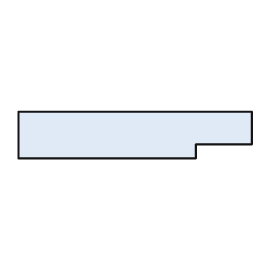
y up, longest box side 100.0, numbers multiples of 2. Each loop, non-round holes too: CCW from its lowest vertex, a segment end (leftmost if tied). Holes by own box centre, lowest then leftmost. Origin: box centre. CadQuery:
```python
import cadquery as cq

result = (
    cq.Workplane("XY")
    .moveTo(-50.0, -10.0)
    .lineTo(26.0, -10.0)
    .lineTo(26.0, -4.0)
    .lineTo(50.0, -4.0)
    .lineTo(50.0, 10.0)
    .lineTo(-50.0, 10.0)
    .close()
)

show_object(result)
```